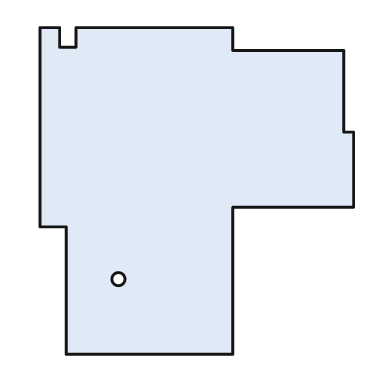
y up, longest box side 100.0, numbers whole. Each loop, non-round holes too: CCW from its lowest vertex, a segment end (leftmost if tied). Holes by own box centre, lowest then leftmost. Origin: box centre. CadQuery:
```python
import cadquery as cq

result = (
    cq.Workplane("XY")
    .moveTo(-40.0, -50.0)
    .lineTo(11.0, -50.0)
    .lineTo(11.0, -5.0)
    .lineTo(48.0, -5.0)
    .lineTo(48.0, 18.0)
    .lineTo(45.0, 18.0)
    .lineTo(45.0, 43.0)
    .lineTo(11.0, 43.0)
    .lineTo(11.0, 50.0)
    .lineTo(-37.0, 50.0)
    .lineTo(-37.0, 44.0)
    .lineTo(-42.0, 44.0)
    .lineTo(-42.0, 50.0)
    .lineTo(-48.0, 50.0)
    .lineTo(-48.0, -11.0)
    .lineTo(-40.0, -11.0)
    .close()
    .moveTo(-24.0, -27.0)
    .circle(2.0)
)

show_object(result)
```